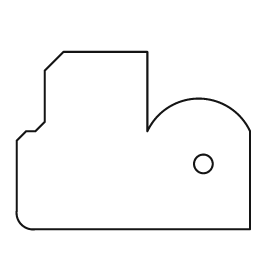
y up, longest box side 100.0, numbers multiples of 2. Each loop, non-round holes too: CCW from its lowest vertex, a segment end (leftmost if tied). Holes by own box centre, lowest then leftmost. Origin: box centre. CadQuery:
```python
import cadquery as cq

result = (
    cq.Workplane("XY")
    .moveTo(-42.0, -38.0)
    .lineTo(50.0, -38.0)
    .lineTo(50.0, 4.0)
    .threePointArc((28.0, 18.0), (6.0, 4.0))
    .lineTo(6.0, 38.0)
    .lineTo(-30.0, 38.0)
    .lineTo(-38.0, 30.0)
    .lineTo(-38.0, 8.0)
    .lineTo(-42.0, 4.0)
    .lineTo(-46.0, 4.0)
    .lineTo(-50.0, 0.0)
    .lineTo(-50.0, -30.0)
    .threePointArc((-48.0, -36.0), (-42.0, -38.0))
    .close()
    .moveTo(30.0, -10.0)
    .circle(4.0)
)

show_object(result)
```